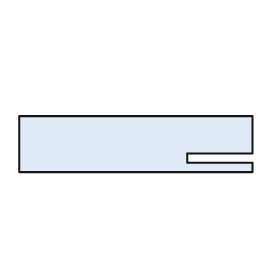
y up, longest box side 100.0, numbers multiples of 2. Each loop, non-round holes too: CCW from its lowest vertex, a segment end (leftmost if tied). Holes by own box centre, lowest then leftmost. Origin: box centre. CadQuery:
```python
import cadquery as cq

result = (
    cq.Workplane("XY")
    .moveTo(-50.0, -12.0)
    .lineTo(50.0, -12.0)
    .lineTo(50.0, -8.0)
    .lineTo(22.0, -8.0)
    .lineTo(22.0, -4.0)
    .lineTo(50.0, -4.0)
    .lineTo(50.0, 12.0)
    .lineTo(-50.0, 12.0)
    .close()
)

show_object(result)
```